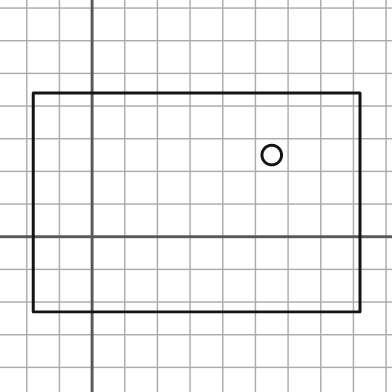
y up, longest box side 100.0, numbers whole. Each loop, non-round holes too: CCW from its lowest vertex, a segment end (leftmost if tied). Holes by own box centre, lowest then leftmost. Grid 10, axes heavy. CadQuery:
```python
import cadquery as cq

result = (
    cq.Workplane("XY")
    .moveTo(-18.0, -23.0)
    .lineTo(82.0, -23.0)
    .lineTo(82.0, 44.0)
    .lineTo(-18.0, 44.0)
    .close()
    .moveTo(55.0, 25.0)
    .circle(3.0)
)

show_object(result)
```